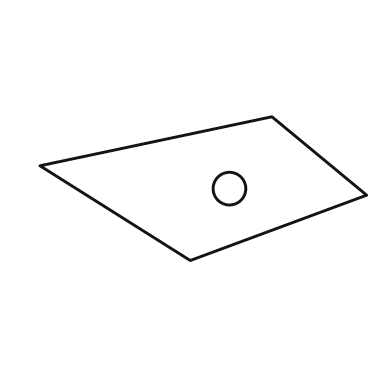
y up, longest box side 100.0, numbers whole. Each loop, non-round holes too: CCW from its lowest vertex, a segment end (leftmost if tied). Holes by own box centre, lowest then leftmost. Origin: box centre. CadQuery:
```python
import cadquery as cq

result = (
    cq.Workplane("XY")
    .moveTo(-4.0, -22.0)
    .lineTo(50.0, -2.0)
    .lineTo(21.0, 22.0)
    .lineTo(-50.0, 7.0)
    .close()
    .moveTo(8.0, 0.0)
    .circle(5.0)
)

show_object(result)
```